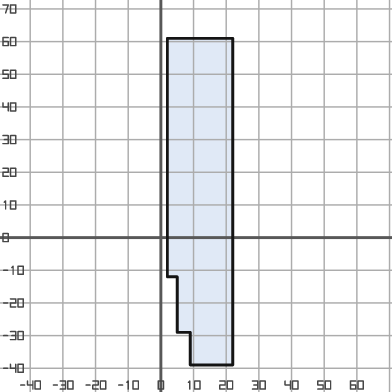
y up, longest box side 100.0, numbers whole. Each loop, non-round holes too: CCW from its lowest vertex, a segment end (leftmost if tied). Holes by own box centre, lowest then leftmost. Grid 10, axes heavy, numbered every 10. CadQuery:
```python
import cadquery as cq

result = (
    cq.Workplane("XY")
    .moveTo(9.0, -39.0)
    .lineTo(22.0, -39.0)
    .lineTo(22.0, 61.0)
    .lineTo(2.0, 61.0)
    .lineTo(2.0, -12.0)
    .lineTo(5.0, -12.0)
    .lineTo(5.0, -29.0)
    .lineTo(9.0, -29.0)
    .close()
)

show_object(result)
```